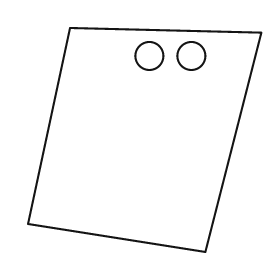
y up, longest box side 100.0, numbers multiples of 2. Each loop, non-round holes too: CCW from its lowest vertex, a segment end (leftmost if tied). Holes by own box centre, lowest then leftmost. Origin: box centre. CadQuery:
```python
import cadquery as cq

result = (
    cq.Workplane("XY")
    .moveTo(26.0, -48.0)
    .lineTo(50.0, 46.0)
    .lineTo(-32.0, 48.0)
    .lineTo(-50.0, -36.0)
    .close()
    .moveTo(2.0, 36.0)
    .circle(6.0)
    .moveTo(20.0, 36.0)
    .circle(6.0)
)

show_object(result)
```